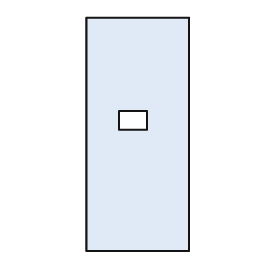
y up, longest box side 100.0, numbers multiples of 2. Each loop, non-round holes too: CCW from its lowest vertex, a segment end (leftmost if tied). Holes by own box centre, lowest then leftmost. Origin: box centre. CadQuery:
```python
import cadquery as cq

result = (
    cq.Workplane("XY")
    .moveTo(-22.0, -50.0)
    .lineTo(22.0, -50.0)
    .lineTo(22.0, 50.0)
    .lineTo(-22.0, 50.0)
    .close()
    .moveTo(-8.0, 2.0)
    .lineTo(4.0, 2.0)
    .lineTo(4.0, 10.0)
    .lineTo(-8.0, 10.0)
    .close()
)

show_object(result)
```